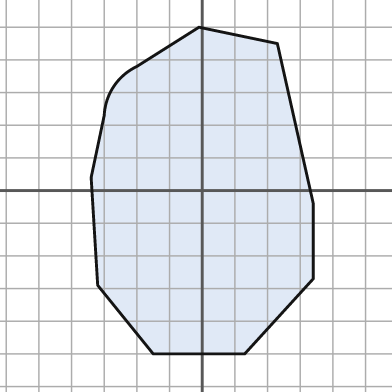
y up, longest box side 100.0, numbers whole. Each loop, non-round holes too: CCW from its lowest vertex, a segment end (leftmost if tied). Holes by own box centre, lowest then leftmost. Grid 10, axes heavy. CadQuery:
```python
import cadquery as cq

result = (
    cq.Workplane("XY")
    .moveTo(-15.0, -50.0)
    .lineTo(13.0, -50.0)
    .lineTo(34.0, -27.0)
    .lineTo(34.0, -4.0)
    .lineTo(23.0, 45.0)
    .lineTo(-1.0, 50.0)
    .lineTo(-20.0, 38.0)
    .threePointArc((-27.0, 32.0), (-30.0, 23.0))
    .lineTo(-34.0, 4.0)
    .lineTo(-32.0, -29.0)
    .close()
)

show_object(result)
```